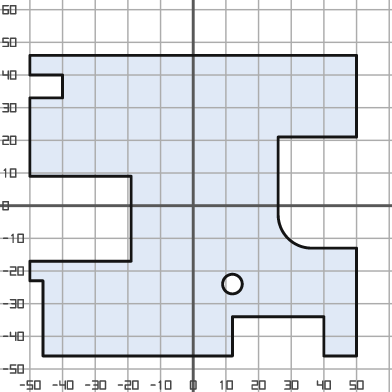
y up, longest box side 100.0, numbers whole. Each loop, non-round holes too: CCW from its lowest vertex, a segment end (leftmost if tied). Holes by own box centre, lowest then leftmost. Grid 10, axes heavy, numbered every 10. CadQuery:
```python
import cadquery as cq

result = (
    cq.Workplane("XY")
    .moveTo(-46.0, -46.0)
    .lineTo(12.0, -46.0)
    .lineTo(12.0, -34.0)
    .lineTo(40.0, -34.0)
    .lineTo(40.0, -46.0)
    .lineTo(50.0, -46.0)
    .lineTo(50.0, -13.0)
    .lineTo(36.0, -13.0)
    .threePointArc((29.0, -10.0), (26.0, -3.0))
    .lineTo(26.0, 21.0)
    .lineTo(50.0, 21.0)
    .lineTo(50.0, 46.0)
    .lineTo(-50.0, 46.0)
    .lineTo(-50.0, 40.0)
    .lineTo(-40.0, 40.0)
    .lineTo(-40.0, 33.0)
    .lineTo(-50.0, 33.0)
    .lineTo(-50.0, 9.0)
    .lineTo(-19.0, 9.0)
    .lineTo(-19.0, -17.0)
    .lineTo(-50.0, -17.0)
    .lineTo(-50.0, -23.0)
    .lineTo(-46.0, -23.0)
    .close()
    .moveTo(12.0, -24.0)
    .circle(3.0)
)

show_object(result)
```